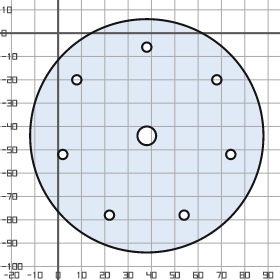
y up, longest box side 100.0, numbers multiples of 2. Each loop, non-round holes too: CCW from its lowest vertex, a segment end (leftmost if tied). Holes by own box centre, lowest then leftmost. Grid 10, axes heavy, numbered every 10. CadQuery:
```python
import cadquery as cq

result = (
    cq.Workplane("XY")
    .moveTo(38.0, -44.0)
    .circle(50.0)
    .moveTo(22.0, -78.0)
    .circle(2.0)
    .moveTo(54.0, -78.0)
    .circle(2.0)
    .moveTo(2.0, -52.0)
    .circle(2.0)
    .moveTo(74.0, -52.0)
    .circle(2.0)
    .moveTo(38.0, -44.0)
    .circle(4.0)
    .moveTo(8.0, -20.0)
    .circle(2.0)
    .moveTo(68.0, -20.0)
    .circle(2.0)
    .moveTo(38.0, -6.0)
    .circle(2.0)
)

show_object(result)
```